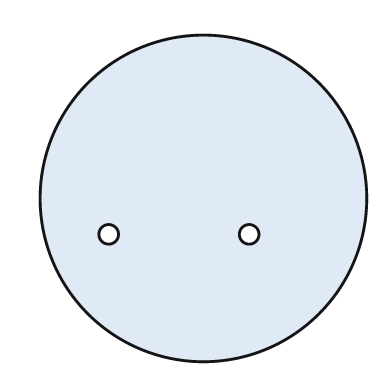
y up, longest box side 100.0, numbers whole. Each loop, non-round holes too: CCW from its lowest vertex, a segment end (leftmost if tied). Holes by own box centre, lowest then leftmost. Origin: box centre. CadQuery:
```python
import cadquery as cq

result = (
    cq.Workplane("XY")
    .moveTo(0.0, 0.0)
    .circle(50.0)
    .moveTo(-29.0, -11.0)
    .circle(3.0)
    .moveTo(14.0, -11.0)
    .circle(3.0)
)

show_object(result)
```